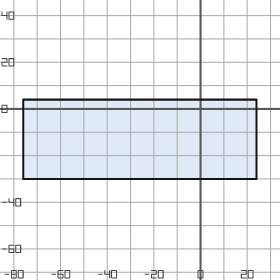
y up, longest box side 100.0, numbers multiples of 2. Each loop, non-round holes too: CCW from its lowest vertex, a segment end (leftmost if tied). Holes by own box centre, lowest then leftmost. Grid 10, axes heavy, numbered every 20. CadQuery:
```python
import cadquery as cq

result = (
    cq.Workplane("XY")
    .moveTo(-76.0, -30.0)
    .lineTo(24.0, -30.0)
    .lineTo(24.0, 4.0)
    .lineTo(-76.0, 4.0)
    .close()
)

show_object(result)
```